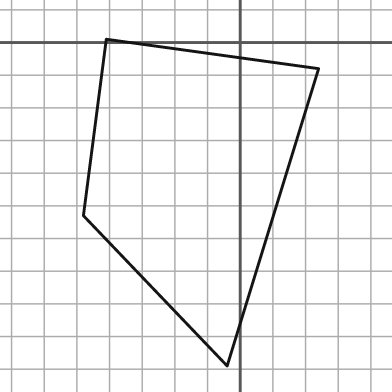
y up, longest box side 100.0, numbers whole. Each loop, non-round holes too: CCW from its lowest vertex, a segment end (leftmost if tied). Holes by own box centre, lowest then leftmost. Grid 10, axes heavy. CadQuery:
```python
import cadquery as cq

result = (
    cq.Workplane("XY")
    .moveTo(-4.0, -99.0)
    .lineTo(24.0, -8.0)
    .lineTo(-41.0, 1.0)
    .lineTo(-48.0, -53.0)
    .close()
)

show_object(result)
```